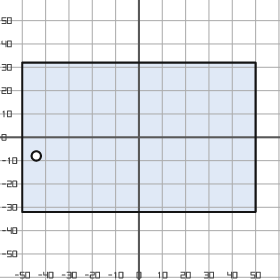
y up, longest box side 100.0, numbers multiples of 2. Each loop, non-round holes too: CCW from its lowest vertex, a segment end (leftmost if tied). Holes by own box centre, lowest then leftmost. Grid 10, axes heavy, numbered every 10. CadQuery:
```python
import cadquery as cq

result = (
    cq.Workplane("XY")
    .moveTo(-50.0, -32.0)
    .lineTo(50.0, -32.0)
    .lineTo(50.0, 32.0)
    .lineTo(-50.0, 32.0)
    .close()
    .moveTo(-44.0, -8.0)
    .circle(2.0)
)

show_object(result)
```